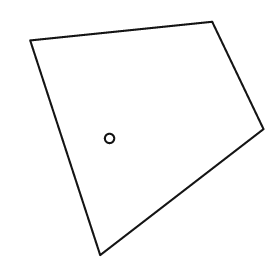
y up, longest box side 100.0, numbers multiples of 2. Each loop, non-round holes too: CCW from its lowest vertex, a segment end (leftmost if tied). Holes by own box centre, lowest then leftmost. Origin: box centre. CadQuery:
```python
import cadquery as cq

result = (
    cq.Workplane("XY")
    .moveTo(-20.0, -50.0)
    .lineTo(50.0, 4.0)
    .lineTo(28.0, 50.0)
    .lineTo(-50.0, 42.0)
    .close()
    .moveTo(-16.0, 0.0)
    .circle(2.0)
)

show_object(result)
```